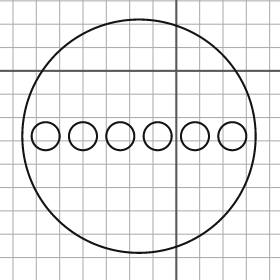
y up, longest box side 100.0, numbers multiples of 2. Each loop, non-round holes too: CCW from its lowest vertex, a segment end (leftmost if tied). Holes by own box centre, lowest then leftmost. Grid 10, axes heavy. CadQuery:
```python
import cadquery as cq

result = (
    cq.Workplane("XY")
    .moveTo(-16.0, -28.0)
    .circle(50.0)
    .moveTo(-56.0, -28.0)
    .circle(6.0)
    .moveTo(-40.0, -28.0)
    .circle(6.0)
    .moveTo(-24.0, -28.0)
    .circle(6.0)
    .moveTo(-8.0, -28.0)
    .circle(6.0)
    .moveTo(8.0, -28.0)
    .circle(6.0)
    .moveTo(24.0, -28.0)
    .circle(6.0)
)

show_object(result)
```